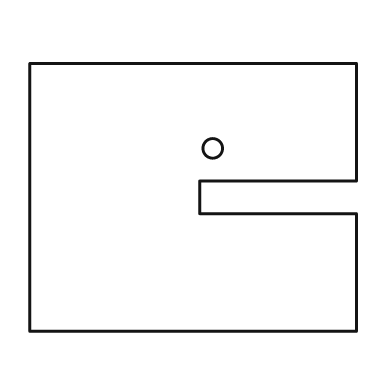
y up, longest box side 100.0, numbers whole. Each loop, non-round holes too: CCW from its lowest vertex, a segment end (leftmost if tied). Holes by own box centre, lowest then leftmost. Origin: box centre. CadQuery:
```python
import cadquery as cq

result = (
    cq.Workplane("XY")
    .moveTo(-50.0, -41.0)
    .lineTo(50.0, -41.0)
    .lineTo(50.0, -5.0)
    .lineTo(2.0, -5.0)
    .lineTo(2.0, 5.0)
    .lineTo(50.0, 5.0)
    .lineTo(50.0, 41.0)
    .lineTo(-50.0, 41.0)
    .close()
    .moveTo(6.0, 15.0)
    .circle(3.0)
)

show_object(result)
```